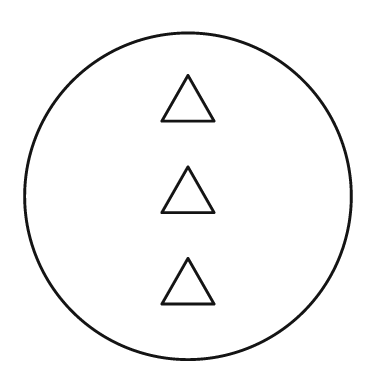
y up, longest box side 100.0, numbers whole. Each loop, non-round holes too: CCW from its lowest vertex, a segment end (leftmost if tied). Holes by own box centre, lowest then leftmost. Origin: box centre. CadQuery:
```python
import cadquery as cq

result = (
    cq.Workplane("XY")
    .moveTo(0.0, 0.0)
    .circle(50.0)
    .moveTo(-8.0, -33.0)
    .lineTo(8.0, -33.0)
    .lineTo(0.0, -19.0)
    .close()
    .moveTo(-8.0, -5.0)
    .lineTo(8.0, -5.0)
    .lineTo(0.0, 9.0)
    .close()
    .moveTo(-8.0, 23.0)
    .lineTo(8.0, 23.0)
    .lineTo(0.0, 37.0)
    .close()
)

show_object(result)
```